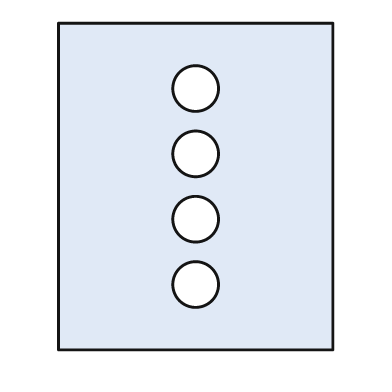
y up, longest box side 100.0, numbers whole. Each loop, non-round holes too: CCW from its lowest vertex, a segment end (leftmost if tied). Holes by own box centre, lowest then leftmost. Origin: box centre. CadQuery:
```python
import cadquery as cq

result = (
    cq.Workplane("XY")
    .moveTo(-42.0, -50.0)
    .lineTo(42.0, -50.0)
    .lineTo(42.0, 50.0)
    .lineTo(-42.0, 50.0)
    .close()
    .moveTo(0.0, -30.0)
    .circle(7.0)
    .moveTo(0.0, -10.0)
    .circle(7.0)
    .moveTo(0.0, 10.0)
    .circle(7.0)
    .moveTo(0.0, 30.0)
    .circle(7.0)
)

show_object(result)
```